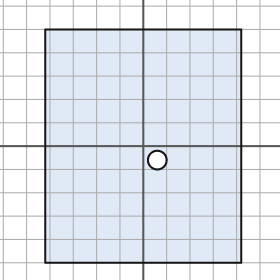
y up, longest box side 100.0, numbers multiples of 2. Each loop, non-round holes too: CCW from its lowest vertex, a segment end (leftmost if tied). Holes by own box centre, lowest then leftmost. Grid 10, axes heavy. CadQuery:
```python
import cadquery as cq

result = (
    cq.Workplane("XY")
    .moveTo(-42.0, -50.0)
    .lineTo(42.0, -50.0)
    .lineTo(42.0, 50.0)
    .lineTo(-42.0, 50.0)
    .close()
    .moveTo(6.0, -6.0)
    .circle(4.0)
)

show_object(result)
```